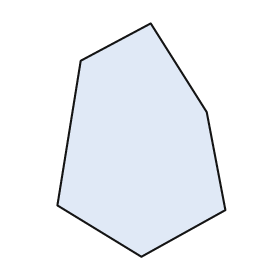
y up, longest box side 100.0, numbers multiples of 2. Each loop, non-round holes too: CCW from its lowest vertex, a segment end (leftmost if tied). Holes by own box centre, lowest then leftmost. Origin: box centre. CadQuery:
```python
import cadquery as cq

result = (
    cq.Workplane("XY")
    .moveTo(0.0, -50.0)
    .lineTo(36.0, -30.0)
    .lineTo(28.0, 12.0)
    .lineTo(4.0, 50.0)
    .lineTo(-26.0, 34.0)
    .lineTo(-36.0, -28.0)
    .close()
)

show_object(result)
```